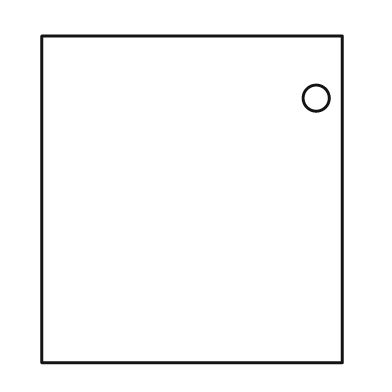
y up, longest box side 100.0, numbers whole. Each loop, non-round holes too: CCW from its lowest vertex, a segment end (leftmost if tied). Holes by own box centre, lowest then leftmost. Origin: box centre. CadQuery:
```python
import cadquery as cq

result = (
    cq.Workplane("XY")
    .moveTo(-46.0, -50.0)
    .lineTo(46.0, -50.0)
    .lineTo(46.0, 50.0)
    .lineTo(-46.0, 50.0)
    .close()
    .moveTo(38.0, 31.0)
    .circle(4.0)
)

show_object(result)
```